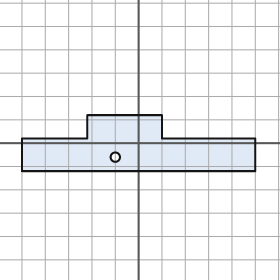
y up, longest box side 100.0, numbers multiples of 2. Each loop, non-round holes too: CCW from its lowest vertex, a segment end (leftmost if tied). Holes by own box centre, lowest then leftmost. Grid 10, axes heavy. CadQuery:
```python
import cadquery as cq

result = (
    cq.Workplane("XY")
    .moveTo(-50.0, -12.0)
    .lineTo(50.0, -12.0)
    .lineTo(50.0, 2.0)
    .lineTo(10.0, 2.0)
    .lineTo(10.0, 12.0)
    .lineTo(-22.0, 12.0)
    .lineTo(-22.0, 2.0)
    .lineTo(-50.0, 2.0)
    .close()
    .moveTo(-10.0, -6.0)
    .circle(2.0)
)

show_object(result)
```